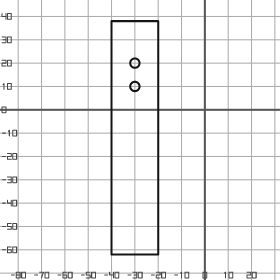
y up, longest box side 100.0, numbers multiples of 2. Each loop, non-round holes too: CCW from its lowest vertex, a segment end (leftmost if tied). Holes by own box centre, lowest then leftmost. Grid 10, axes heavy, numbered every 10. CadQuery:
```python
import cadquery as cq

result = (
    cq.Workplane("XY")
    .moveTo(-40.0, -62.0)
    .lineTo(-20.0, -62.0)
    .lineTo(-20.0, 38.0)
    .lineTo(-40.0, 38.0)
    .close()
    .moveTo(-30.0, 10.0)
    .circle(2.0)
    .moveTo(-30.0, 20.0)
    .circle(2.0)
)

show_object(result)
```